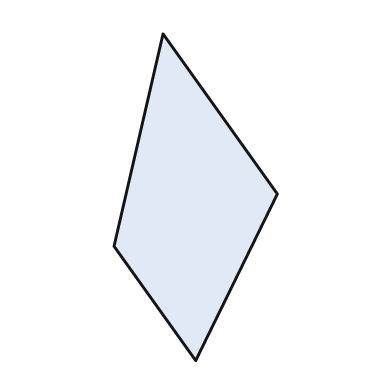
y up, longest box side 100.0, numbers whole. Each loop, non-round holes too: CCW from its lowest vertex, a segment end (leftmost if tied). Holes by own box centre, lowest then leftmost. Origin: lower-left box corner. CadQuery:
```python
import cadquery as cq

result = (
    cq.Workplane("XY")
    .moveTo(25.0, 0.0)
    .lineTo(50.0, 51.0)
    .lineTo(15.0, 100.0)
    .lineTo(0.0, 35.0)
    .close()
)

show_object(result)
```